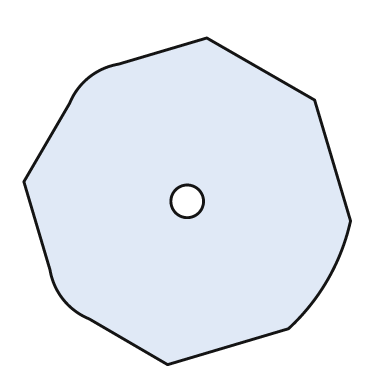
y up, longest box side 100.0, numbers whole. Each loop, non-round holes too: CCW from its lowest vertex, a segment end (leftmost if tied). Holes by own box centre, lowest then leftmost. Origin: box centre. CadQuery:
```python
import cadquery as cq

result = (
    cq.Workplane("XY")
    .moveTo(-6.0, -50.0)
    .lineTo(31.0, -39.0)
    .threePointArc((43.0, -24.0), (50.0, -6.0))
    .lineTo(39.0, 31.0)
    .lineTo(6.0, 50.0)
    .lineTo(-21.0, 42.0)
    .threePointArc((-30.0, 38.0), (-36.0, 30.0))
    .lineTo(-50.0, 6.0)
    .lineTo(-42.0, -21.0)
    .threePointArc((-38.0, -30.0), (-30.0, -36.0))
    .close()
    .moveTo(0.0, 0.0)
    .circle(5.0)
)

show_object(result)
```